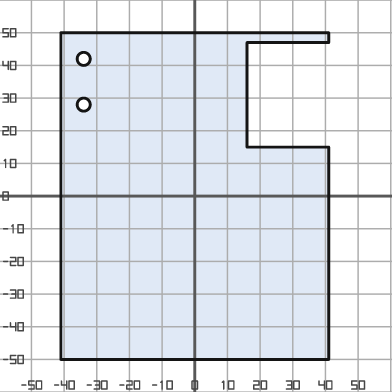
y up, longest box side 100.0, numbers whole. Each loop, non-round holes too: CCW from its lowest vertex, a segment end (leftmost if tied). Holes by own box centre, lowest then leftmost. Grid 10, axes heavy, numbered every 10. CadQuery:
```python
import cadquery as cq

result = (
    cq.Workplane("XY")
    .moveTo(-41.0, -50.0)
    .lineTo(41.0, -50.0)
    .lineTo(41.0, 15.0)
    .lineTo(16.0, 15.0)
    .lineTo(16.0, 47.0)
    .lineTo(41.0, 47.0)
    .lineTo(41.0, 50.0)
    .lineTo(-41.0, 50.0)
    .close()
    .moveTo(-34.0, 28.0)
    .circle(2.0)
    .moveTo(-34.0, 42.0)
    .circle(2.0)
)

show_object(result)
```